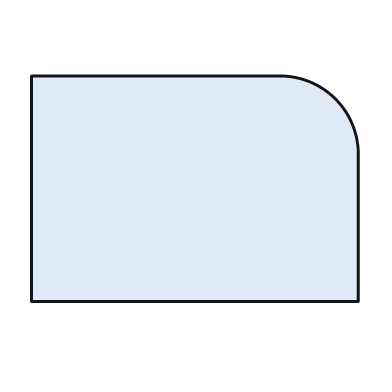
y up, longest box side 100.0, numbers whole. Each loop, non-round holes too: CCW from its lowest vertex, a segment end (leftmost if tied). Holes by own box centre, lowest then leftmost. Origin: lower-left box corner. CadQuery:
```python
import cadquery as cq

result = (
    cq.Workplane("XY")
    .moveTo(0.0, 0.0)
    .lineTo(100.0, 0.0)
    .lineTo(100.0, 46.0)
    .threePointArc((93.0, 62.0), (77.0, 69.0))
    .lineTo(0.0, 69.0)
    .close()
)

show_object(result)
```